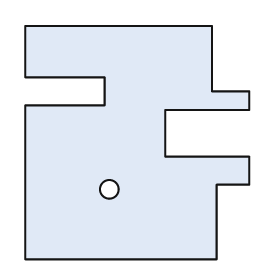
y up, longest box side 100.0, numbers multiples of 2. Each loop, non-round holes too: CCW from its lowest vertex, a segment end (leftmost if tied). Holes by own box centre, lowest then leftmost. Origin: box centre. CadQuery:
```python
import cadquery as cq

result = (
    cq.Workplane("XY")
    .moveTo(-48.0, -50.0)
    .lineTo(34.0, -50.0)
    .lineTo(34.0, -18.0)
    .lineTo(48.0, -18.0)
    .lineTo(48.0, -6.0)
    .lineTo(12.0, -6.0)
    .lineTo(12.0, 14.0)
    .lineTo(48.0, 14.0)
    .lineTo(48.0, 22.0)
    .lineTo(32.0, 22.0)
    .lineTo(32.0, 50.0)
    .lineTo(-48.0, 50.0)
    .lineTo(-48.0, 28.0)
    .lineTo(-14.0, 28.0)
    .lineTo(-14.0, 16.0)
    .lineTo(-48.0, 16.0)
    .close()
    .moveTo(-12.0, -20.0)
    .circle(4.0)
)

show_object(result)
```